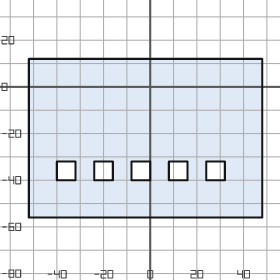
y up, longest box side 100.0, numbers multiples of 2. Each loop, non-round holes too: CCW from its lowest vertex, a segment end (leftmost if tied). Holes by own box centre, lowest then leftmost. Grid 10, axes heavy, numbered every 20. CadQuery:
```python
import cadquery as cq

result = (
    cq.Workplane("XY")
    .moveTo(-52.0, -56.0)
    .lineTo(48.0, -56.0)
    .lineTo(48.0, 12.0)
    .lineTo(-52.0, 12.0)
    .close()
    .moveTo(-40.0, -40.0)
    .lineTo(-32.0, -40.0)
    .lineTo(-32.0, -32.0)
    .lineTo(-40.0, -32.0)
    .close()
    .moveTo(-24.0, -40.0)
    .lineTo(-16.0, -40.0)
    .lineTo(-16.0, -32.0)
    .lineTo(-24.0, -32.0)
    .close()
    .moveTo(-8.0, -40.0)
    .lineTo(0.0, -40.0)
    .lineTo(0.0, -32.0)
    .lineTo(-8.0, -32.0)
    .close()
    .moveTo(8.0, -40.0)
    .lineTo(16.0, -40.0)
    .lineTo(16.0, -32.0)
    .lineTo(8.0, -32.0)
    .close()
    .moveTo(24.0, -40.0)
    .lineTo(32.0, -40.0)
    .lineTo(32.0, -32.0)
    .lineTo(24.0, -32.0)
    .close()
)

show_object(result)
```